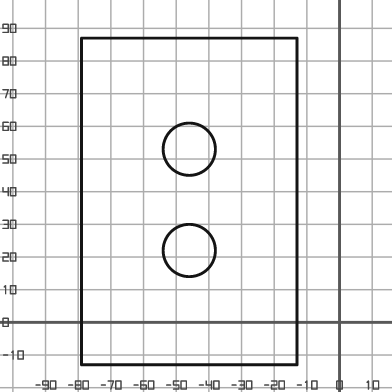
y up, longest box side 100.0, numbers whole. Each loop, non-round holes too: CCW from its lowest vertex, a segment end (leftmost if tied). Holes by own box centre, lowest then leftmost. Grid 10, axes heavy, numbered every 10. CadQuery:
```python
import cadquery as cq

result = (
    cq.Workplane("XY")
    .moveTo(-79.0, -13.0)
    .lineTo(-13.0, -13.0)
    .lineTo(-13.0, 87.0)
    .lineTo(-79.0, 87.0)
    .close()
    .moveTo(-46.0, 22.0)
    .circle(8.0)
    .moveTo(-46.0, 53.0)
    .circle(8.0)
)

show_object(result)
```